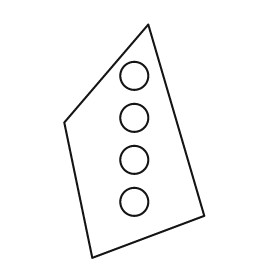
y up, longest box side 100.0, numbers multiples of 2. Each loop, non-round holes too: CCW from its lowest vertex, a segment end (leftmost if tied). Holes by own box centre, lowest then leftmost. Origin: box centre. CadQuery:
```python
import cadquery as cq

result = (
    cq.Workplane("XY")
    .moveTo(-18.0, -50.0)
    .lineTo(30.0, -32.0)
    .lineTo(6.0, 50.0)
    .lineTo(-30.0, 8.0)
    .close()
    .moveTo(0.0, -26.0)
    .circle(6.0)
    .moveTo(0.0, -8.0)
    .circle(6.0)
    .moveTo(0.0, 10.0)
    .circle(6.0)
    .moveTo(0.0, 28.0)
    .circle(6.0)
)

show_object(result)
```